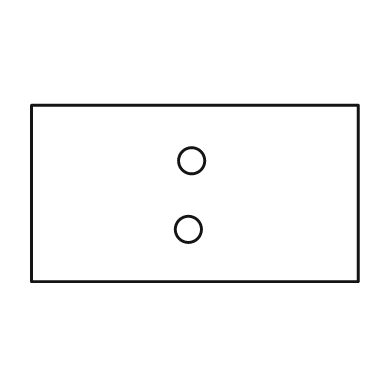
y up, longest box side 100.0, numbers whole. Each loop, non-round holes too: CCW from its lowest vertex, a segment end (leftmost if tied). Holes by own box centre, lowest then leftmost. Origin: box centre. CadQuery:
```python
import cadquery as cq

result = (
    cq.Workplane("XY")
    .moveTo(-50.0, -27.0)
    .lineTo(50.0, -27.0)
    .lineTo(50.0, 27.0)
    .lineTo(-50.0, 27.0)
    .close()
    .moveTo(-2.0, -11.0)
    .circle(4.0)
    .moveTo(-1.0, 10.0)
    .circle(4.0)
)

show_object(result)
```